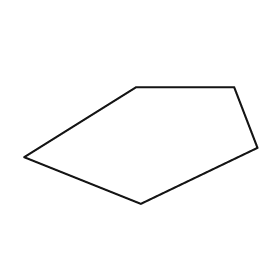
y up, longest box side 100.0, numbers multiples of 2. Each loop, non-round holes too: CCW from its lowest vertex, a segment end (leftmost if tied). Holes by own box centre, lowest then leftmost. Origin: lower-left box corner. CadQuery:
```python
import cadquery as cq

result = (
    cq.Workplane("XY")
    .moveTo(50.0, 0.0)
    .lineTo(100.0, 24.0)
    .lineTo(90.0, 50.0)
    .lineTo(48.0, 50.0)
    .lineTo(0.0, 20.0)
    .close()
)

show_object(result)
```